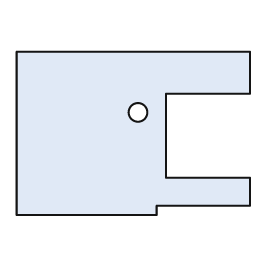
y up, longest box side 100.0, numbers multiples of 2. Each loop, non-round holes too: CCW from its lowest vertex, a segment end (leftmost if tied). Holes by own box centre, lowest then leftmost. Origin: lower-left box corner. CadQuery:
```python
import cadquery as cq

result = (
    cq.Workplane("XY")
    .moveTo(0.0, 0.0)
    .lineTo(60.0, 0.0)
    .lineTo(60.0, 4.0)
    .lineTo(100.0, 4.0)
    .lineTo(100.0, 16.0)
    .lineTo(64.0, 16.0)
    .lineTo(64.0, 52.0)
    .lineTo(100.0, 52.0)
    .lineTo(100.0, 70.0)
    .lineTo(0.0, 70.0)
    .close()
    .moveTo(52.0, 44.0)
    .circle(4.0)
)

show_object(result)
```